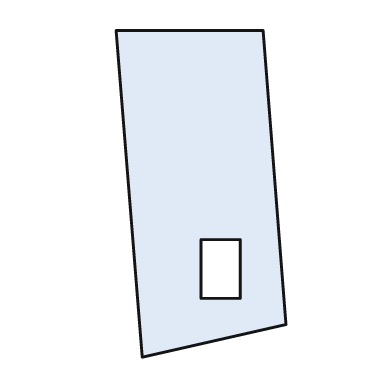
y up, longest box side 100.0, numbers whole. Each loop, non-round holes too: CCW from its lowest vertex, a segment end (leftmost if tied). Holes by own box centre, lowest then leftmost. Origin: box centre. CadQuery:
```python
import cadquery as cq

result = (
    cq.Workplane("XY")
    .moveTo(-18.0, -50.0)
    .lineTo(26.0, -40.0)
    .lineTo(19.0, 50.0)
    .lineTo(-26.0, 50.0)
    .close()
    .moveTo(0.0, -32.0)
    .lineTo(12.0, -32.0)
    .lineTo(12.0, -14.0)
    .lineTo(0.0, -14.0)
    .close()
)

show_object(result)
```